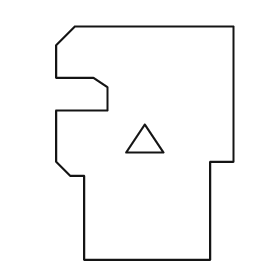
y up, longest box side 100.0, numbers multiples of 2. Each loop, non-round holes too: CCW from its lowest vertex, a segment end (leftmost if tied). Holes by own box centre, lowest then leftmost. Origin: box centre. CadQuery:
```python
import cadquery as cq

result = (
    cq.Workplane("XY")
    .moveTo(-26.0, -50.0)
    .lineTo(28.0, -50.0)
    .lineTo(28.0, -8.0)
    .lineTo(38.0, -8.0)
    .lineTo(38.0, 50.0)
    .lineTo(-30.0, 50.0)
    .lineTo(-38.0, 42.0)
    .lineTo(-38.0, 28.0)
    .lineTo(-22.0, 28.0)
    .lineTo(-16.0, 24.0)
    .lineTo(-16.0, 14.0)
    .lineTo(-38.0, 14.0)
    .lineTo(-38.0, -8.0)
    .lineTo(-32.0, -14.0)
    .lineTo(-26.0, -14.0)
    .close()
    .moveTo(-8.0, -4.0)
    .lineTo(8.0, -4.0)
    .lineTo(0.0, 8.0)
    .close()
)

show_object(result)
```